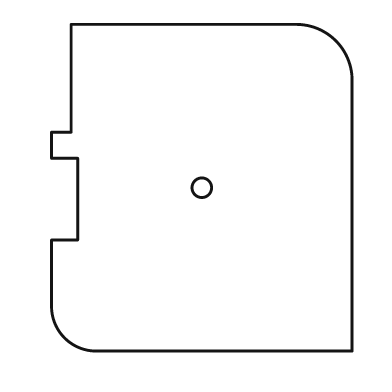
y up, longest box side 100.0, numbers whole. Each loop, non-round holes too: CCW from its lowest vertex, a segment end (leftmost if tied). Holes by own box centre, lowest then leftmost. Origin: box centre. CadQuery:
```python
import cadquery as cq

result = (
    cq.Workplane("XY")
    .moveTo(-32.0, -50.0)
    .lineTo(46.0, -50.0)
    .lineTo(46.0, 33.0)
    .threePointArc((41.0, 45.0), (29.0, 50.0))
    .lineTo(-40.0, 50.0)
    .lineTo(-40.0, 17.0)
    .lineTo(-46.0, 17.0)
    .lineTo(-46.0, 9.0)
    .lineTo(-38.0, 9.0)
    .lineTo(-38.0, -16.0)
    .lineTo(-46.0, -16.0)
    .lineTo(-46.0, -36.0)
    .threePointArc((-42.0, -46.0), (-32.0, -50.0))
    .close()
    .moveTo(0.0, 0.0)
    .circle(3.0)
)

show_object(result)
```